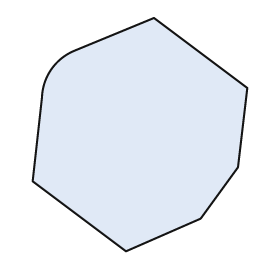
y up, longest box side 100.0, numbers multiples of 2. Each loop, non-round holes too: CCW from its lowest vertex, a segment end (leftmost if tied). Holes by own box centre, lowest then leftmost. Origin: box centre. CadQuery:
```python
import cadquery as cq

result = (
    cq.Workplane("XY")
    .moveTo(-6.0, -50.0)
    .lineTo(26.0, -36.0)
    .lineTo(42.0, -14.0)
    .lineTo(46.0, 20.0)
    .lineTo(6.0, 50.0)
    .lineTo(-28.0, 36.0)
    .threePointArc((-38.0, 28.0), (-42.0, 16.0))
    .lineTo(-46.0, -20.0)
    .close()
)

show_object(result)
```